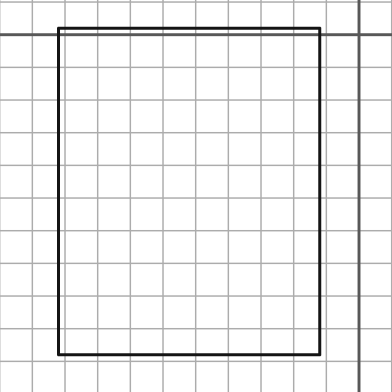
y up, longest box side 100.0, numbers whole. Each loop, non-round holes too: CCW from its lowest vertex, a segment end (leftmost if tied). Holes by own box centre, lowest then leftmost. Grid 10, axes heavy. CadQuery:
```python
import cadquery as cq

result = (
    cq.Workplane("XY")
    .moveTo(-92.0, -98.0)
    .lineTo(-12.0, -98.0)
    .lineTo(-12.0, 2.0)
    .lineTo(-92.0, 2.0)
    .close()
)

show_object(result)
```